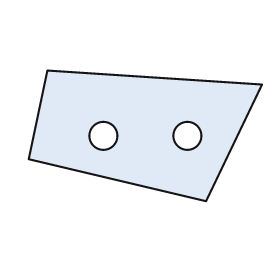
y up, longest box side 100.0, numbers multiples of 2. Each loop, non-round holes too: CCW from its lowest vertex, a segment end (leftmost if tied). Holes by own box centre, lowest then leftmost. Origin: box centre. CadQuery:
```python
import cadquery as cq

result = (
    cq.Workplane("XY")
    .moveTo(26.0, -28.0)
    .lineTo(50.0, 22.0)
    .lineTo(-42.0, 28.0)
    .lineTo(-50.0, -10.0)
    .close()
    .moveTo(-18.0, 0.0)
    .circle(6.0)
    .moveTo(18.0, 0.0)
    .circle(6.0)
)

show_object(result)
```